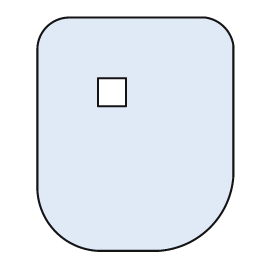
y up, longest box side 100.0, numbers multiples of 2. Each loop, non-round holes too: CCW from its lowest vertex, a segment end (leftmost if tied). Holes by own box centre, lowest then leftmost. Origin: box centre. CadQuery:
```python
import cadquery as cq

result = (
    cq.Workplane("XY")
    .moveTo(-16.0, -50.0)
    .lineTo(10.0, -50.0)
    .threePointArc((32.0, -40.0), (42.0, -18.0))
    .lineTo(42.0, 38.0)
    .threePointArc((38.0, 46.0), (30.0, 50.0))
    .lineTo(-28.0, 50.0)
    .threePointArc((-38.0, 46.0), (-42.0, 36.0))
    .lineTo(-42.0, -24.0)
    .threePointArc((-34.0, -42.0), (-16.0, -50.0))
    .close()
    .moveTo(-16.0, 12.0)
    .lineTo(-4.0, 12.0)
    .lineTo(-4.0, 24.0)
    .lineTo(-16.0, 24.0)
    .close()
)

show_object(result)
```